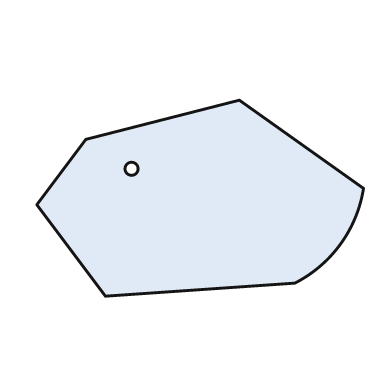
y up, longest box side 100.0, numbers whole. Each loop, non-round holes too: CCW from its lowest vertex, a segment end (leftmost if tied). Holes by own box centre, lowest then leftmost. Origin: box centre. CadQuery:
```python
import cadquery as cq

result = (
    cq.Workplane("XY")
    .moveTo(-29.0, -30.0)
    .lineTo(29.0, -26.0)
    .threePointArc((43.0, -14.0), (50.0, 3.0))
    .lineTo(12.0, 30.0)
    .lineTo(-35.0, 18.0)
    .lineTo(-50.0, -2.0)
    .close()
    .moveTo(-21.0, 9.0)
    .circle(2.0)
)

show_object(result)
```